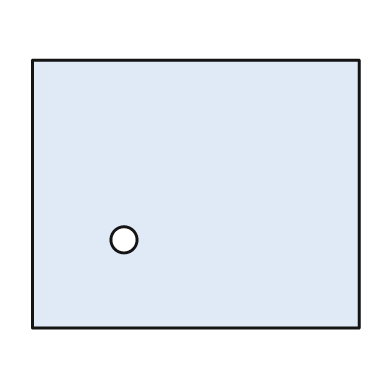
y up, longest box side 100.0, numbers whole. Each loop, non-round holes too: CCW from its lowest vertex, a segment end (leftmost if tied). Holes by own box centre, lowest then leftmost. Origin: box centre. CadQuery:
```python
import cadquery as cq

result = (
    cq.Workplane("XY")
    .moveTo(-50.0, -41.0)
    .lineTo(50.0, -41.0)
    .lineTo(50.0, 41.0)
    .lineTo(-50.0, 41.0)
    .close()
    .moveTo(-22.0, -14.0)
    .circle(4.0)
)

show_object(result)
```